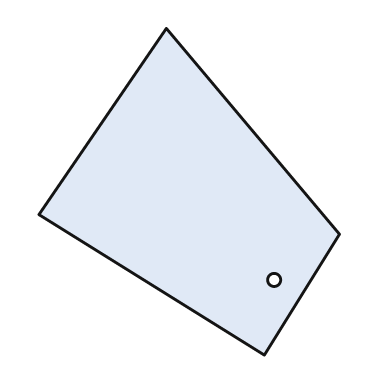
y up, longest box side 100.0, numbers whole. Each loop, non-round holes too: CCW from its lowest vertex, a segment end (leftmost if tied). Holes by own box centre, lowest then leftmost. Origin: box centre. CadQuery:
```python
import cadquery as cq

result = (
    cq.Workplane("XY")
    .moveTo(23.0, -50.0)
    .lineTo(46.0, -13.0)
    .lineTo(-7.0, 50.0)
    .lineTo(-46.0, -7.0)
    .close()
    .moveTo(26.0, -27.0)
    .circle(2.0)
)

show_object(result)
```